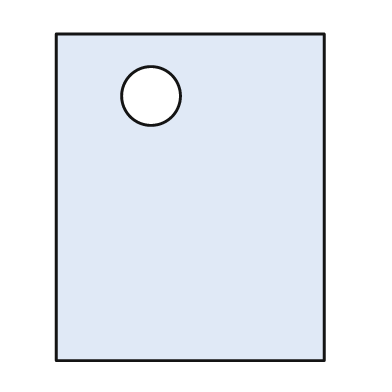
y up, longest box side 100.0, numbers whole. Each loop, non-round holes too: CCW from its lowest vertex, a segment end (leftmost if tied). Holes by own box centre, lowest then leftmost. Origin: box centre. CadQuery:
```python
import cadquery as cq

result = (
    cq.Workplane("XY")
    .moveTo(-41.0, -50.0)
    .lineTo(41.0, -50.0)
    .lineTo(41.0, 50.0)
    .lineTo(-41.0, 50.0)
    .close()
    .moveTo(-12.0, 31.0)
    .circle(9.0)
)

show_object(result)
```